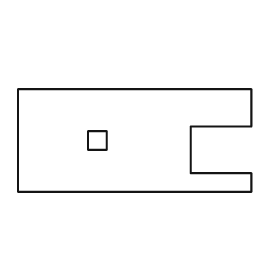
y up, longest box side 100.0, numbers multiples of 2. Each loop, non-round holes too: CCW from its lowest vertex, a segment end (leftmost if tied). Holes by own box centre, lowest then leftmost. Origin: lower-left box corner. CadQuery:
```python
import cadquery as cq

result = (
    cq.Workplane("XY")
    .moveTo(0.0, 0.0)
    .lineTo(100.0, 0.0)
    .lineTo(100.0, 8.0)
    .lineTo(74.0, 8.0)
    .lineTo(74.0, 28.0)
    .lineTo(100.0, 28.0)
    .lineTo(100.0, 44.0)
    .lineTo(0.0, 44.0)
    .close()
    .moveTo(30.0, 18.0)
    .lineTo(38.0, 18.0)
    .lineTo(38.0, 26.0)
    .lineTo(30.0, 26.0)
    .close()
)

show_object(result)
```